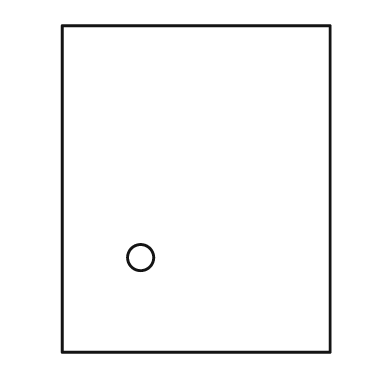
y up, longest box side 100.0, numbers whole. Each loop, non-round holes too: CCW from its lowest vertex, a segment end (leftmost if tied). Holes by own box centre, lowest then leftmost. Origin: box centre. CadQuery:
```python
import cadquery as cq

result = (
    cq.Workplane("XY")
    .moveTo(-41.0, -50.0)
    .lineTo(41.0, -50.0)
    .lineTo(41.0, 50.0)
    .lineTo(-41.0, 50.0)
    .close()
    .moveTo(-17.0, -21.0)
    .circle(4.0)
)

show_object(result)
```